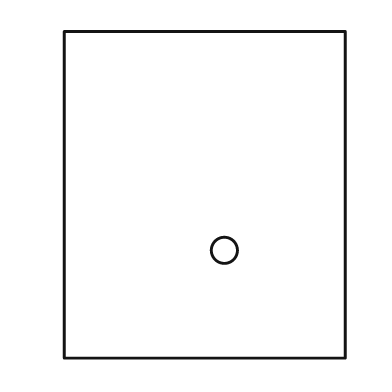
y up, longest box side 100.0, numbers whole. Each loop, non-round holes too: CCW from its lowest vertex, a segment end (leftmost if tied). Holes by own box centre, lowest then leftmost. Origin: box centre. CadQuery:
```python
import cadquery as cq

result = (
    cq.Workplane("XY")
    .moveTo(-43.0, -50.0)
    .lineTo(43.0, -50.0)
    .lineTo(43.0, 50.0)
    .lineTo(-43.0, 50.0)
    .close()
    .moveTo(6.0, -17.0)
    .circle(4.0)
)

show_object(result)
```